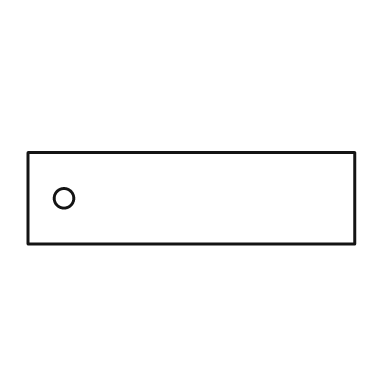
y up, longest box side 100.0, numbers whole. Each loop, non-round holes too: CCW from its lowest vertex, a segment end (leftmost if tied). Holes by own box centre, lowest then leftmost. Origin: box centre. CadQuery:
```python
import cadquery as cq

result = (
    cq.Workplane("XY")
    .moveTo(-50.0, -14.0)
    .lineTo(50.0, -14.0)
    .lineTo(50.0, 14.0)
    .lineTo(-50.0, 14.0)
    .close()
    .moveTo(-39.0, 0.0)
    .circle(3.0)
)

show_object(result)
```